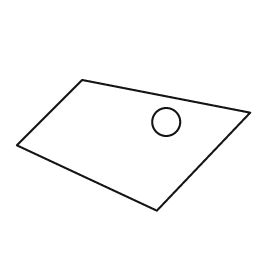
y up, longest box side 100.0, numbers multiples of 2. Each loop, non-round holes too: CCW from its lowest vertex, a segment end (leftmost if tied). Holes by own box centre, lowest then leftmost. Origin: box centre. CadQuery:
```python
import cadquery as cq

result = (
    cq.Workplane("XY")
    .moveTo(10.0, -28.0)
    .lineTo(50.0, 14.0)
    .lineTo(-22.0, 28.0)
    .lineTo(-50.0, 0.0)
    .close()
    .moveTo(14.0, 10.0)
    .circle(6.0)
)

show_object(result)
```